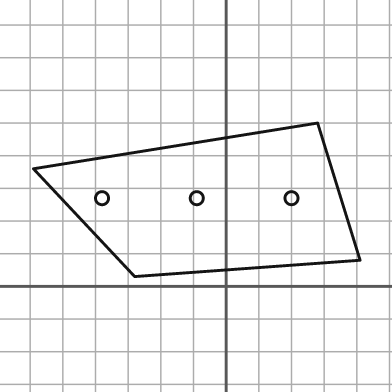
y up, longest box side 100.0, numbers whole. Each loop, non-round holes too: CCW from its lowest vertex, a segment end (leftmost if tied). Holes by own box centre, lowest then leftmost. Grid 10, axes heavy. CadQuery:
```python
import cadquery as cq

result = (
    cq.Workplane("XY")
    .moveTo(-28.0, 3.0)
    .lineTo(41.0, 8.0)
    .lineTo(28.0, 50.0)
    .lineTo(-59.0, 36.0)
    .close()
    .moveTo(-38.0, 27.0)
    .circle(2.0)
    .moveTo(-9.0, 27.0)
    .circle(2.0)
    .moveTo(20.0, 27.0)
    .circle(2.0)
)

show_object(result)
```